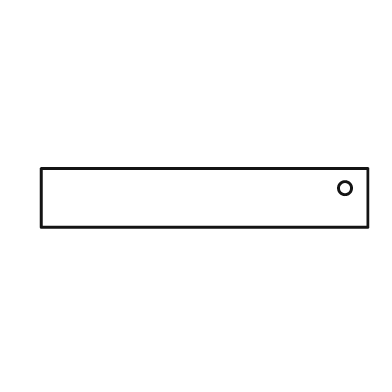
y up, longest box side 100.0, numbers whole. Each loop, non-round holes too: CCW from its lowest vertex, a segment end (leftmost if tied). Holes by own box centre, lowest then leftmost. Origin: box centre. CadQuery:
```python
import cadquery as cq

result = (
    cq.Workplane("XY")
    .moveTo(-50.0, -9.0)
    .lineTo(50.0, -9.0)
    .lineTo(50.0, 9.0)
    .lineTo(-50.0, 9.0)
    .close()
    .moveTo(43.0, 3.0)
    .circle(2.0)
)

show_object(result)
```